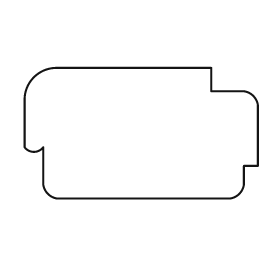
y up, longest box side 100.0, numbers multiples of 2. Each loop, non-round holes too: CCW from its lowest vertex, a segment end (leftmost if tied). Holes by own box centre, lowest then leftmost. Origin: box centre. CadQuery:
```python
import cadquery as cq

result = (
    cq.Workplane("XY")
    .moveTo(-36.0, -28.0)
    .lineTo(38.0, -28.0)
    .threePointArc((42.0, -26.0), (44.0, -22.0))
    .lineTo(44.0, -14.0)
    .lineTo(50.0, -14.0)
    .lineTo(50.0, 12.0)
    .threePointArc((48.0, 16.0), (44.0, 18.0))
    .lineTo(30.0, 18.0)
    .lineTo(30.0, 28.0)
    .lineTo(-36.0, 28.0)
    .threePointArc((-46.0, 24.0), (-50.0, 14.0))
    .lineTo(-50.0, -6.0)
    .threePointArc((-46.0, -8.0), (-42.0, -6.0))
    .lineTo(-42.0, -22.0)
    .threePointArc((-40.0, -26.0), (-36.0, -28.0))
    .close()
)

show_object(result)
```